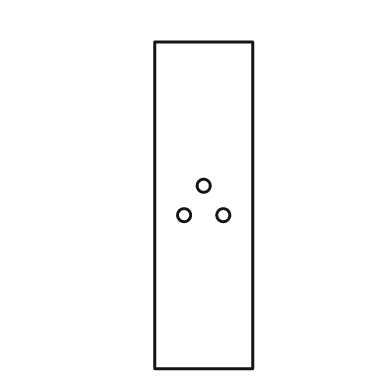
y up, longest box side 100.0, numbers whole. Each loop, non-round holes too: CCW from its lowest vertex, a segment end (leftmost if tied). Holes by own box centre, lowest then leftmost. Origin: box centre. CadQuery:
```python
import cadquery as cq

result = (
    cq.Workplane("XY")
    .moveTo(-15.0, -50.0)
    .lineTo(15.0, -50.0)
    .lineTo(15.0, 50.0)
    .lineTo(-15.0, 50.0)
    .close()
    .moveTo(-6.0, -3.0)
    .circle(2.0)
    .moveTo(6.0, -3.0)
    .circle(2.0)
    .moveTo(0.0, 6.0)
    .circle(2.0)
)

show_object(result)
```